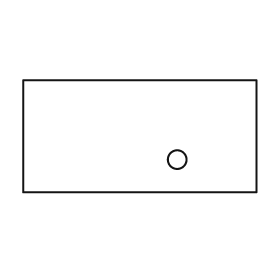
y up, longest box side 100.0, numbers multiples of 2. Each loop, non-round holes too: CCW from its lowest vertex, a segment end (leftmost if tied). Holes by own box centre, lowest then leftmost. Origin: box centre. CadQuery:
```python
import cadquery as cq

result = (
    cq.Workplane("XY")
    .moveTo(-50.0, -24.0)
    .lineTo(50.0, -24.0)
    .lineTo(50.0, 24.0)
    .lineTo(-50.0, 24.0)
    .close()
    .moveTo(16.0, -10.0)
    .circle(4.0)
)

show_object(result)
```